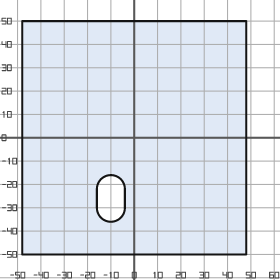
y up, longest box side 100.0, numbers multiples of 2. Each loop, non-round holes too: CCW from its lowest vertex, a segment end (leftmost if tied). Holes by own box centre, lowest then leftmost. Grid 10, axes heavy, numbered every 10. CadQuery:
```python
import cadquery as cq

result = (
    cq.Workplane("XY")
    .moveTo(-48.0, -50.0)
    .lineTo(48.0, -50.0)
    .lineTo(48.0, 50.0)
    .lineTo(-48.0, 50.0)
    .close()
    .moveTo(-16.0, -30.0)
    .threePointArc((-10.0, -36.0), (-4.0, -30.0))
    .lineTo(-4.0, -22.0)
    .threePointArc((-10.0, -16.0), (-16.0, -22.0))
    .close()
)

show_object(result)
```